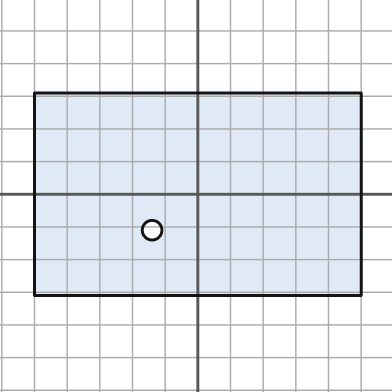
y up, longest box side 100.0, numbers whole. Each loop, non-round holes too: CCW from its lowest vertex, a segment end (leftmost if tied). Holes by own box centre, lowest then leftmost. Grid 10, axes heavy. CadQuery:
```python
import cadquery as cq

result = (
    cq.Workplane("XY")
    .moveTo(-50.0, -31.0)
    .lineTo(50.0, -31.0)
    .lineTo(50.0, 31.0)
    .lineTo(-50.0, 31.0)
    .close()
    .moveTo(-14.0, -11.0)
    .circle(3.0)
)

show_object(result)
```